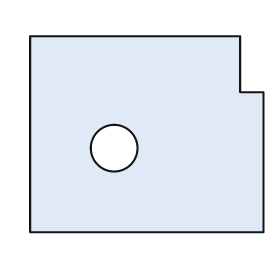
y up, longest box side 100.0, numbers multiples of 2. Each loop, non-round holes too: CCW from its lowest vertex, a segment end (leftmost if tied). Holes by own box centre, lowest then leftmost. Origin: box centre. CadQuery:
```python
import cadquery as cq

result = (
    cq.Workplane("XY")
    .moveTo(-50.0, -42.0)
    .lineTo(50.0, -42.0)
    .lineTo(50.0, 18.0)
    .lineTo(40.0, 18.0)
    .lineTo(40.0, 42.0)
    .lineTo(-50.0, 42.0)
    .close()
    .moveTo(-14.0, -6.0)
    .circle(10.0)
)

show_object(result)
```